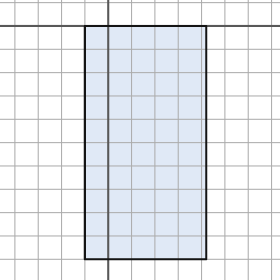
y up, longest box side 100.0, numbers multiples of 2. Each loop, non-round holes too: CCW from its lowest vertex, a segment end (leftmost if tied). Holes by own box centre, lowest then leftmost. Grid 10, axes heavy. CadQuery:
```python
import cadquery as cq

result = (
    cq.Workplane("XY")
    .moveTo(-10.0, -100.0)
    .lineTo(42.0, -100.0)
    .lineTo(42.0, 0.0)
    .lineTo(-10.0, 0.0)
    .close()
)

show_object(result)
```